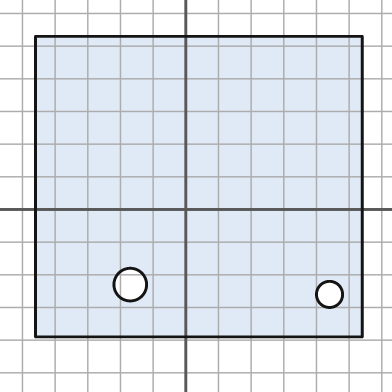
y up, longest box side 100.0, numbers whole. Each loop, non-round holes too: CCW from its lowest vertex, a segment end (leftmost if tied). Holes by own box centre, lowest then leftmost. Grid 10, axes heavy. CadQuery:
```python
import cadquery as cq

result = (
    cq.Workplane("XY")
    .moveTo(-46.0, -39.0)
    .lineTo(54.0, -39.0)
    .lineTo(54.0, 53.0)
    .lineTo(-46.0, 53.0)
    .close()
    .moveTo(44.0, -26.0)
    .circle(4.0)
    .moveTo(-17.0, -23.0)
    .circle(5.0)
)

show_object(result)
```